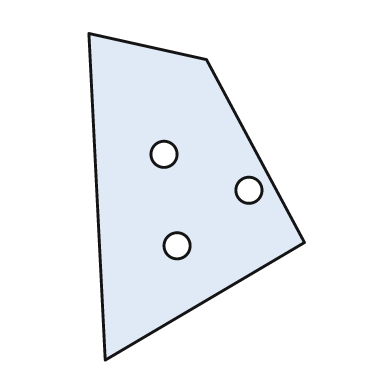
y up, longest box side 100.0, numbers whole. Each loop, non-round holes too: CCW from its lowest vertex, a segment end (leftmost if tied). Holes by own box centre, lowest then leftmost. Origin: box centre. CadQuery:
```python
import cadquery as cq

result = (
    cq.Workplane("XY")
    .moveTo(-28.0, -50.0)
    .lineTo(33.0, -14.0)
    .lineTo(3.0, 42.0)
    .lineTo(-33.0, 50.0)
    .close()
    .moveTo(-6.0, -15.0)
    .circle(4.0)
    .moveTo(16.0, 2.0)
    .circle(4.0)
    .moveTo(-10.0, 13.0)
    .circle(4.0)
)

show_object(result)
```